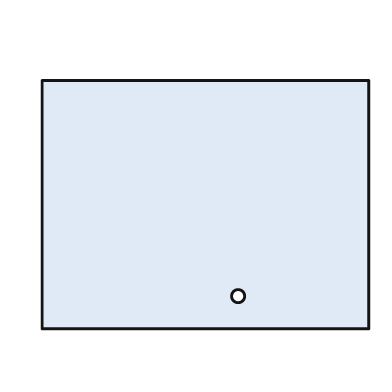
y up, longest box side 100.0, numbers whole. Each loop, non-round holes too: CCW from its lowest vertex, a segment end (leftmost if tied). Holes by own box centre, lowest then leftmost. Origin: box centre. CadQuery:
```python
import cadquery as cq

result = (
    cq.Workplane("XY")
    .moveTo(-50.0, -38.0)
    .lineTo(50.0, -38.0)
    .lineTo(50.0, 38.0)
    .lineTo(-50.0, 38.0)
    .close()
    .moveTo(10.0, -28.0)
    .circle(2.0)
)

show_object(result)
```